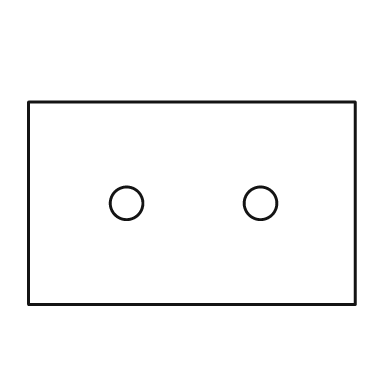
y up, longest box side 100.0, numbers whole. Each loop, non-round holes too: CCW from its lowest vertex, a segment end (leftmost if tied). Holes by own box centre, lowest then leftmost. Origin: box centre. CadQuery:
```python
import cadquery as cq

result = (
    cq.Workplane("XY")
    .moveTo(-50.0, -31.0)
    .lineTo(50.0, -31.0)
    .lineTo(50.0, 31.0)
    .lineTo(-50.0, 31.0)
    .close()
    .moveTo(-20.0, 0.0)
    .circle(5.0)
    .moveTo(21.0, 0.0)
    .circle(5.0)
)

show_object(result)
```